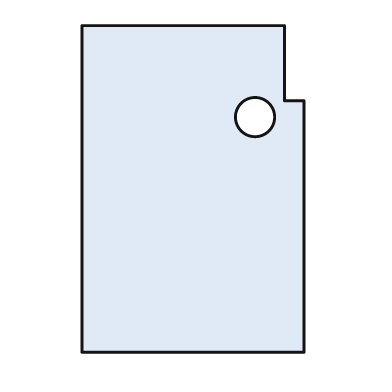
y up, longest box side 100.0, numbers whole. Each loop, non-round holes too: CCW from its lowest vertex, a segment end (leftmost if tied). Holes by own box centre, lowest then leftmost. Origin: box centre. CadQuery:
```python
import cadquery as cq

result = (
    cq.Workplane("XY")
    .moveTo(-34.0, -50.0)
    .lineTo(34.0, -50.0)
    .lineTo(34.0, 27.0)
    .lineTo(28.0, 27.0)
    .lineTo(28.0, 50.0)
    .lineTo(-34.0, 50.0)
    .close()
    .moveTo(19.0, 22.0)
    .circle(6.0)
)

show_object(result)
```